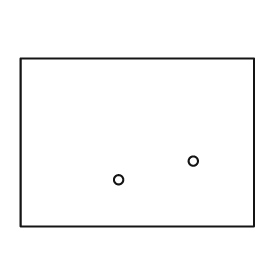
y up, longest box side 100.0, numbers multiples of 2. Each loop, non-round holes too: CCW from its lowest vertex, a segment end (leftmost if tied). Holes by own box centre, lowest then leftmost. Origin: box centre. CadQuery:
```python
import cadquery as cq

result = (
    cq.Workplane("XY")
    .moveTo(-50.0, -36.0)
    .lineTo(50.0, -36.0)
    .lineTo(50.0, 36.0)
    .lineTo(-50.0, 36.0)
    .close()
    .moveTo(-8.0, -16.0)
    .circle(2.0)
    .moveTo(24.0, -8.0)
    .circle(2.0)
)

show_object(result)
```